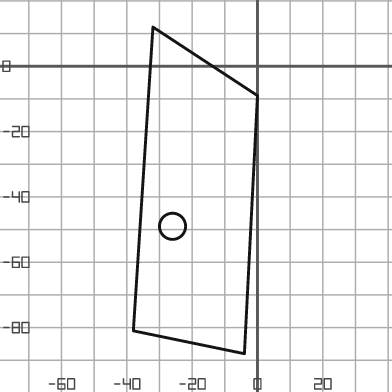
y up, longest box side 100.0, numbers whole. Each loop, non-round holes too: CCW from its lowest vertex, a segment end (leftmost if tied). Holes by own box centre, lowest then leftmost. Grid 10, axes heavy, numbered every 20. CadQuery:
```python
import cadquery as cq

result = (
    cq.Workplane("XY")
    .moveTo(-4.0, -88.0)
    .lineTo(0.0, -9.0)
    .lineTo(-32.0, 12.0)
    .lineTo(-38.0, -81.0)
    .close()
    .moveTo(-26.0, -49.0)
    .circle(4.0)
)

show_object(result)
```